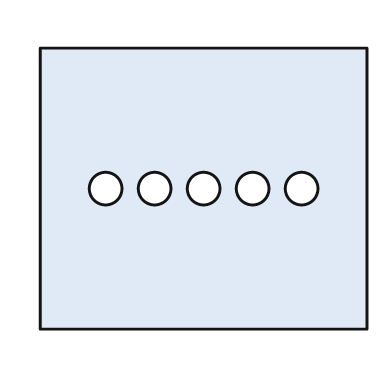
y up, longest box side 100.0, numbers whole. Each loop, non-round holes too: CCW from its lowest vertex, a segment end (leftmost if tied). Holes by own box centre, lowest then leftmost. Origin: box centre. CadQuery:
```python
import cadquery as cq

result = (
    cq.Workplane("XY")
    .moveTo(-50.0, -43.0)
    .lineTo(50.0, -43.0)
    .lineTo(50.0, 43.0)
    .lineTo(-50.0, 43.0)
    .close()
    .moveTo(-30.0, 0.0)
    .circle(5.0)
    .moveTo(-15.0, 0.0)
    .circle(5.0)
    .moveTo(0.0, 0.0)
    .circle(5.0)
    .moveTo(15.0, 0.0)
    .circle(5.0)
    .moveTo(30.0, 0.0)
    .circle(5.0)
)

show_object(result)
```